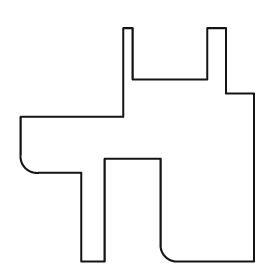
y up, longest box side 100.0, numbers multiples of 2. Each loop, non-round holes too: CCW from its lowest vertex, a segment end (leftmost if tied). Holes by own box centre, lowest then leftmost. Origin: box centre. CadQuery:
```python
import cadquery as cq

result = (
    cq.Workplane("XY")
    .moveTo(-24.0, -50.0)
    .lineTo(-14.0, -50.0)
    .lineTo(-14.0, -6.0)
    .lineTo(10.0, -6.0)
    .lineTo(10.0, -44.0)
    .threePointArc((12.0, -48.0), (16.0, -50.0))
    .lineTo(50.0, -50.0)
    .lineTo(50.0, 22.0)
    .lineTo(38.0, 22.0)
    .lineTo(38.0, 50.0)
    .lineTo(30.0, 50.0)
    .lineTo(30.0, 28.0)
    .lineTo(-2.0, 28.0)
    .lineTo(-2.0, 50.0)
    .lineTo(-6.0, 50.0)
    .lineTo(-6.0, 12.0)
    .lineTo(-50.0, 12.0)
    .lineTo(-50.0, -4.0)
    .threePointArc((-48.0, -10.0), (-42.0, -12.0))
    .lineTo(-24.0, -12.0)
    .close()
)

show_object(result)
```